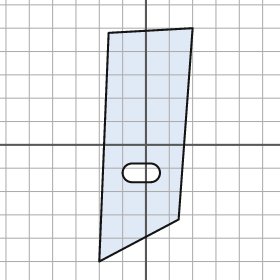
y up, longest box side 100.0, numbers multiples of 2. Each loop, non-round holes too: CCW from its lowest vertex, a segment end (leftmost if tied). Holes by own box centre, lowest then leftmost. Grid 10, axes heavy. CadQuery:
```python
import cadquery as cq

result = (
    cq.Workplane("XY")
    .moveTo(-20.0, -50.0)
    .lineTo(14.0, -32.0)
    .lineTo(20.0, 50.0)
    .lineTo(-16.0, 48.0)
    .close()
    .moveTo(-6.0, -16.0)
    .lineTo(2.0, -16.0)
    .threePointArc((6.0, -12.0), (2.0, -8.0))
    .lineTo(-6.0, -8.0)
    .threePointArc((-10.0, -12.0), (-6.0, -16.0))
    .close()
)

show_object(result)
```